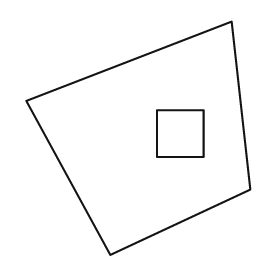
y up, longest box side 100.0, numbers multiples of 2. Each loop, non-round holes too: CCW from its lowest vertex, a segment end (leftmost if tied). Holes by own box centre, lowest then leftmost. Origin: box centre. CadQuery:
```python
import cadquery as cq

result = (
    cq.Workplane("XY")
    .moveTo(-12.0, -50.0)
    .lineTo(48.0, -22.0)
    .lineTo(40.0, 50.0)
    .lineTo(-48.0, 16.0)
    .close()
    .moveTo(8.0, -8.0)
    .lineTo(28.0, -8.0)
    .lineTo(28.0, 12.0)
    .lineTo(8.0, 12.0)
    .close()
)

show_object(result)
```